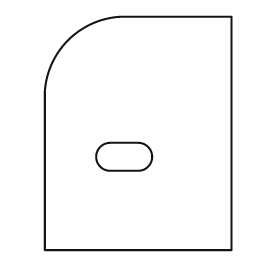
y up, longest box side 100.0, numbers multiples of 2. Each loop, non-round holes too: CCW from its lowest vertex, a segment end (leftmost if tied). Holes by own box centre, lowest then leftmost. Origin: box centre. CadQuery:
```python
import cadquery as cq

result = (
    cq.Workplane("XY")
    .moveTo(-40.0, -50.0)
    .lineTo(40.0, -50.0)
    .lineTo(40.0, 50.0)
    .lineTo(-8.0, 50.0)
    .threePointArc((-30.0, 40.0), (-40.0, 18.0))
    .close()
    .moveTo(-12.0, -16.0)
    .lineTo(0.0, -16.0)
    .threePointArc((6.0, -10.0), (0.0, -4.0))
    .lineTo(-12.0, -4.0)
    .threePointArc((-18.0, -10.0), (-12.0, -16.0))
    .close()
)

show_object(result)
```